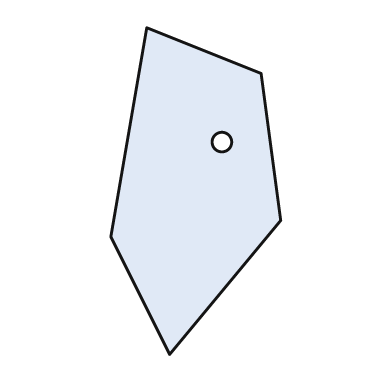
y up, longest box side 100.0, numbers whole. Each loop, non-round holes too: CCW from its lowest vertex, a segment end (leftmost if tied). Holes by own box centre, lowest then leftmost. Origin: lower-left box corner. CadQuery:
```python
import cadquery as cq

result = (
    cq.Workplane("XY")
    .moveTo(18.0, 0.0)
    .lineTo(52.0, 41.0)
    .lineTo(46.0, 86.0)
    .lineTo(11.0, 100.0)
    .lineTo(0.0, 36.0)
    .close()
    .moveTo(34.0, 65.0)
    .circle(3.0)
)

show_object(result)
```